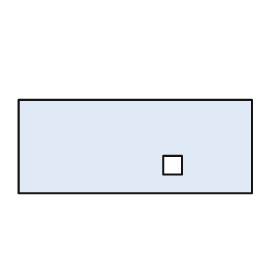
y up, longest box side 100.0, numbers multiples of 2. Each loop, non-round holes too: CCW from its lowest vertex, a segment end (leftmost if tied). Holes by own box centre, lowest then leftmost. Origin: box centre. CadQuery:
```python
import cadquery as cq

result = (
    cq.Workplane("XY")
    .moveTo(-50.0, -20.0)
    .lineTo(50.0, -20.0)
    .lineTo(50.0, 20.0)
    .lineTo(-50.0, 20.0)
    .close()
    .moveTo(12.0, -12.0)
    .lineTo(20.0, -12.0)
    .lineTo(20.0, -4.0)
    .lineTo(12.0, -4.0)
    .close()
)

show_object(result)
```